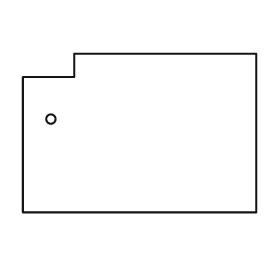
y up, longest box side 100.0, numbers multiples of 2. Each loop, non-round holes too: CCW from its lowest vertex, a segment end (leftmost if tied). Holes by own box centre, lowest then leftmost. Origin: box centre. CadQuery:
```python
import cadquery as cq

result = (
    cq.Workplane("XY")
    .moveTo(-50.0, -34.0)
    .lineTo(50.0, -34.0)
    .lineTo(50.0, 34.0)
    .lineTo(-28.0, 34.0)
    .lineTo(-28.0, 24.0)
    .lineTo(-50.0, 24.0)
    .close()
    .moveTo(-38.0, 6.0)
    .circle(2.0)
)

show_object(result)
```